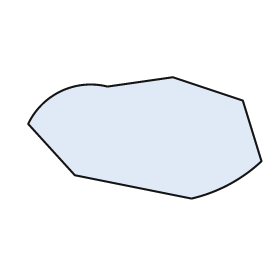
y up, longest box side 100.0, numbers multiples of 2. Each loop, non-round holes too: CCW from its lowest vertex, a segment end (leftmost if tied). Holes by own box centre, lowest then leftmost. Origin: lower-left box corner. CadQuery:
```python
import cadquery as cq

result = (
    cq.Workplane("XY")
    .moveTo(70.0, 0.0)
    .threePointArc((86.0, 6.0), (100.0, 16.0))
    .lineTo(92.0, 42.0)
    .lineTo(62.0, 52.0)
    .lineTo(34.0, 48.0)
    .threePointArc((14.0, 46.0), (0.0, 32.0))
    .lineTo(20.0, 10.0)
    .close()
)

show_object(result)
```